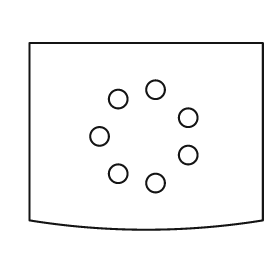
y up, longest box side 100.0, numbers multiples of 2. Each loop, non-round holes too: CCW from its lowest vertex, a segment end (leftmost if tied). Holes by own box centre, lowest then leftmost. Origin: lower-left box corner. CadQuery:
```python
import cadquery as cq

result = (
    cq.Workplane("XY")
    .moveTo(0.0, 4.0)
    .threePointArc((50.0, 0.0), (100.0, 4.0))
    .lineTo(100.0, 80.0)
    .lineTo(0.0, 80.0)
    .close()
    .moveTo(54.0, 20.0)
    .circle(4.0)
    .moveTo(38.0, 24.0)
    .circle(4.0)
    .moveTo(68.0, 32.0)
    .circle(4.0)
    .moveTo(30.0, 40.0)
    .circle(4.0)
    .moveTo(68.0, 48.0)
    .circle(4.0)
    .moveTo(38.0, 56.0)
    .circle(4.0)
    .moveTo(54.0, 60.0)
    .circle(4.0)
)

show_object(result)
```